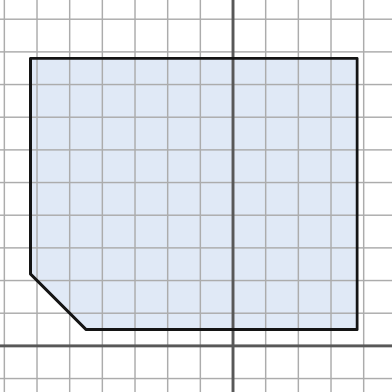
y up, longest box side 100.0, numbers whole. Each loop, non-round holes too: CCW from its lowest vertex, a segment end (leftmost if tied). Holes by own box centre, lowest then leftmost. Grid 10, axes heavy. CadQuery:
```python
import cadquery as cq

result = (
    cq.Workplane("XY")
    .moveTo(-45.0, 5.0)
    .lineTo(38.0, 5.0)
    .lineTo(38.0, 88.0)
    .lineTo(-62.0, 88.0)
    .lineTo(-62.0, 22.0)
    .close()
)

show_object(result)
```